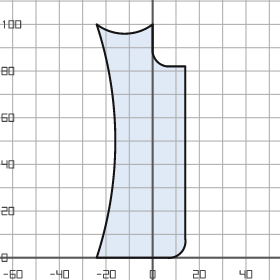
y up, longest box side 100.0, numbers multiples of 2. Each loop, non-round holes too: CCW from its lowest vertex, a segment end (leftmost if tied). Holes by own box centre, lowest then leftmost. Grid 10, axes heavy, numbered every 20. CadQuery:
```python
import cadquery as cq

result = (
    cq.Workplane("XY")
    .moveTo(-24.0, 0.0)
    .lineTo(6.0, 0.0)
    .threePointArc((12.0, 2.0), (14.0, 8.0))
    .lineTo(14.0, 82.0)
    .lineTo(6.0, 82.0)
    .threePointArc((2.0, 84.0), (0.0, 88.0))
    .lineTo(0.0, 100.0)
    .threePointArc((-12.0, 96.0), (-24.0, 100.0))
    .threePointArc((-16.0, 50.0), (-24.0, 0.0))
    .close()
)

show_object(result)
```